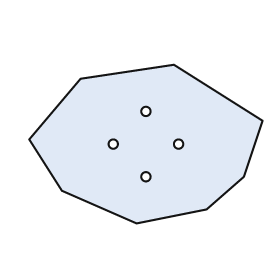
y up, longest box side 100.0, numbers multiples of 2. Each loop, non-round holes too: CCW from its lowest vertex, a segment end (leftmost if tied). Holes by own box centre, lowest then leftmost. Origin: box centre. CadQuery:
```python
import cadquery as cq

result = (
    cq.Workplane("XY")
    .moveTo(-4.0, -34.0)
    .lineTo(26.0, -28.0)
    .lineTo(42.0, -14.0)
    .lineTo(50.0, 10.0)
    .lineTo(12.0, 34.0)
    .lineTo(-28.0, 28.0)
    .lineTo(-50.0, 2.0)
    .lineTo(-36.0, -20.0)
    .close()
    .moveTo(0.0, -14.0)
    .circle(2.0)
    .moveTo(-14.0, 0.0)
    .circle(2.0)
    .moveTo(14.0, 0.0)
    .circle(2.0)
    .moveTo(0.0, 14.0)
    .circle(2.0)
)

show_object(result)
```